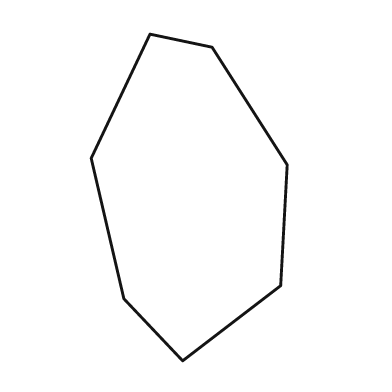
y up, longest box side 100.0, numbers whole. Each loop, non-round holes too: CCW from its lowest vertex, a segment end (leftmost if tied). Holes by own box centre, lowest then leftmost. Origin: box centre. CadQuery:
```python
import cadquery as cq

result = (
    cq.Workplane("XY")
    .moveTo(-2.0, -50.0)
    .lineTo(28.0, -27.0)
    .lineTo(30.0, 10.0)
    .lineTo(7.0, 46.0)
    .lineTo(-12.0, 50.0)
    .lineTo(-30.0, 12.0)
    .lineTo(-20.0, -31.0)
    .close()
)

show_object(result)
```